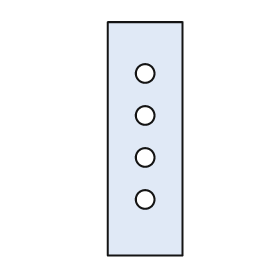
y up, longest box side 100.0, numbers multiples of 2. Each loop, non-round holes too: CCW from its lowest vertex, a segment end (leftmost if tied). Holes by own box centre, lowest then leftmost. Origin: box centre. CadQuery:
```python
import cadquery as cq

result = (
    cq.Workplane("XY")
    .moveTo(-16.0, -50.0)
    .lineTo(16.0, -50.0)
    .lineTo(16.0, 50.0)
    .lineTo(-16.0, 50.0)
    .close()
    .moveTo(0.0, -26.0)
    .circle(4.0)
    .moveTo(0.0, -8.0)
    .circle(4.0)
    .moveTo(0.0, 10.0)
    .circle(4.0)
    .moveTo(0.0, 28.0)
    .circle(4.0)
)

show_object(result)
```